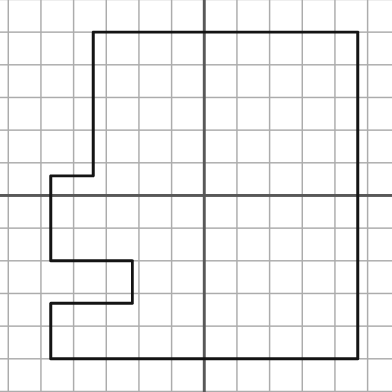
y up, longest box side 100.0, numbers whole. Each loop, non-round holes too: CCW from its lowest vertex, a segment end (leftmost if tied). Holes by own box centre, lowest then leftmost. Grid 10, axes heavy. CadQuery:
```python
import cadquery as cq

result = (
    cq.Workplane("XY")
    .moveTo(-47.0, -50.0)
    .lineTo(47.0, -50.0)
    .lineTo(47.0, 50.0)
    .lineTo(-34.0, 50.0)
    .lineTo(-34.0, 6.0)
    .lineTo(-47.0, 6.0)
    .lineTo(-47.0, -20.0)
    .lineTo(-22.0, -20.0)
    .lineTo(-22.0, -33.0)
    .lineTo(-47.0, -33.0)
    .close()
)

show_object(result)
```